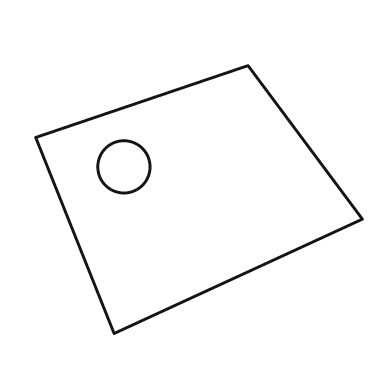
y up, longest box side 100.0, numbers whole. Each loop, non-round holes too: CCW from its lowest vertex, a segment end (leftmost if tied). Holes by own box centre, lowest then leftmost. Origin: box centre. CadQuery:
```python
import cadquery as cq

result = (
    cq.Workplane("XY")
    .moveTo(-26.0, -41.0)
    .lineTo(50.0, -6.0)
    .lineTo(15.0, 41.0)
    .lineTo(-50.0, 19.0)
    .close()
    .moveTo(-23.0, 10.0)
    .circle(8.0)
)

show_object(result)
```